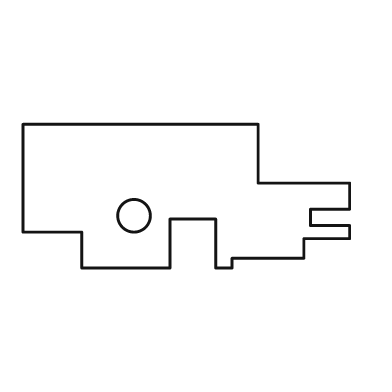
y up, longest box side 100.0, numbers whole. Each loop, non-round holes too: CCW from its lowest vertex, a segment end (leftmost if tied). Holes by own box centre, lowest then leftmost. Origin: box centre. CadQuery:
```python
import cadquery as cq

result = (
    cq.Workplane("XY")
    .moveTo(-32.0, -22.0)
    .lineTo(-5.0, -22.0)
    .lineTo(-5.0, -7.0)
    .lineTo(9.0, -7.0)
    .lineTo(9.0, -22.0)
    .lineTo(14.0, -22.0)
    .lineTo(14.0, -19.0)
    .lineTo(36.0, -19.0)
    .lineTo(36.0, -13.0)
    .lineTo(50.0, -13.0)
    .lineTo(50.0, -9.0)
    .lineTo(38.0, -9.0)
    .lineTo(38.0, -4.0)
    .lineTo(50.0, -4.0)
    .lineTo(50.0, 4.0)
    .lineTo(22.0, 4.0)
    .lineTo(22.0, 22.0)
    .lineTo(-50.0, 22.0)
    .lineTo(-50.0, -11.0)
    .lineTo(-32.0, -11.0)
    .close()
    .moveTo(-16.0, -6.0)
    .circle(5.0)
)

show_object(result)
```